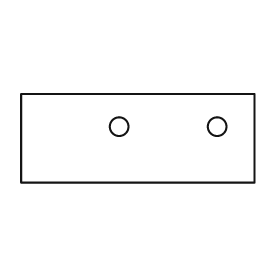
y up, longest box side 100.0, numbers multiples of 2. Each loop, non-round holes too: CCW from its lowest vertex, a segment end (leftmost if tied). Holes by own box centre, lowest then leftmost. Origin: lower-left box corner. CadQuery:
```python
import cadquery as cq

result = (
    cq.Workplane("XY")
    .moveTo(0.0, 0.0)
    .lineTo(100.0, 0.0)
    .lineTo(100.0, 38.0)
    .lineTo(0.0, 38.0)
    .close()
    .moveTo(42.0, 24.0)
    .circle(4.0)
    .moveTo(84.0, 24.0)
    .circle(4.0)
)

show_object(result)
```